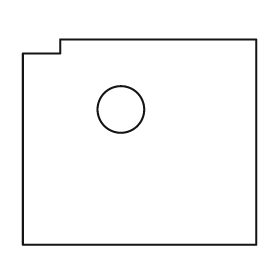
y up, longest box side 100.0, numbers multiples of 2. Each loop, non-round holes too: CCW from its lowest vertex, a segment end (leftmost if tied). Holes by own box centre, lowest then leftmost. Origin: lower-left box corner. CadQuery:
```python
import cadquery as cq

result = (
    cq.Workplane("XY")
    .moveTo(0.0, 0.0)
    .lineTo(100.0, 0.0)
    .lineTo(100.0, 88.0)
    .lineTo(16.0, 88.0)
    .lineTo(16.0, 82.0)
    .lineTo(0.0, 82.0)
    .close()
    .moveTo(42.0, 58.0)
    .circle(10.0)
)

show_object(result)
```